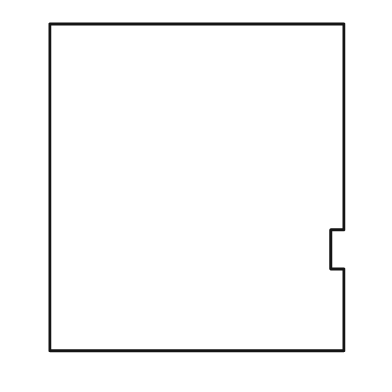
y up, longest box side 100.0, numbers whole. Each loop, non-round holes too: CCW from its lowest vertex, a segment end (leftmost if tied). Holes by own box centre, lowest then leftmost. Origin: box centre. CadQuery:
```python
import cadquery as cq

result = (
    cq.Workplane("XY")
    .moveTo(-45.0, -50.0)
    .lineTo(45.0, -50.0)
    .lineTo(45.0, -25.0)
    .lineTo(41.0, -25.0)
    .lineTo(41.0, -13.0)
    .lineTo(45.0, -13.0)
    .lineTo(45.0, 50.0)
    .lineTo(-45.0, 50.0)
    .close()
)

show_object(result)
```